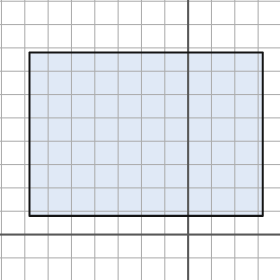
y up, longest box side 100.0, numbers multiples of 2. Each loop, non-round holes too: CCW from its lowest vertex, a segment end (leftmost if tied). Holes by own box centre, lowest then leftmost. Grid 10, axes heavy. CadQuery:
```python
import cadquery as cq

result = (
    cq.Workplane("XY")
    .moveTo(-68.0, 8.0)
    .lineTo(32.0, 8.0)
    .lineTo(32.0, 78.0)
    .lineTo(-68.0, 78.0)
    .close()
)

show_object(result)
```